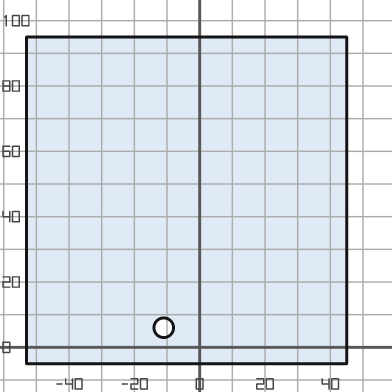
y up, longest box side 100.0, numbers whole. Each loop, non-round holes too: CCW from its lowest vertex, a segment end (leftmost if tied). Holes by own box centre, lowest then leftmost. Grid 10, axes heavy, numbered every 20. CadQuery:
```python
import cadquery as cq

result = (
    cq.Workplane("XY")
    .moveTo(-53.0, -5.0)
    .lineTo(45.0, -5.0)
    .lineTo(45.0, 95.0)
    .lineTo(-53.0, 95.0)
    .close()
    .moveTo(-11.0, 6.0)
    .circle(3.0)
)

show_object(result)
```